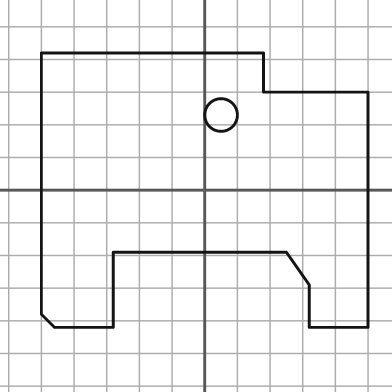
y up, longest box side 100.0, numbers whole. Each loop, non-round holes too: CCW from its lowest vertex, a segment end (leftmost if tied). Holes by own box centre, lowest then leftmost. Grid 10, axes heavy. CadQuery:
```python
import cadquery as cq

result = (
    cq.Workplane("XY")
    .moveTo(-46.0, -42.0)
    .lineTo(-28.0, -42.0)
    .lineTo(-28.0, -19.0)
    .lineTo(25.0, -19.0)
    .lineTo(32.0, -29.0)
    .lineTo(32.0, -42.0)
    .lineTo(50.0, -42.0)
    .lineTo(50.0, 30.0)
    .lineTo(18.0, 30.0)
    .lineTo(18.0, 42.0)
    .lineTo(-50.0, 42.0)
    .lineTo(-50.0, -38.0)
    .close()
    .moveTo(5.0, 23.0)
    .circle(5.0)
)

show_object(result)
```